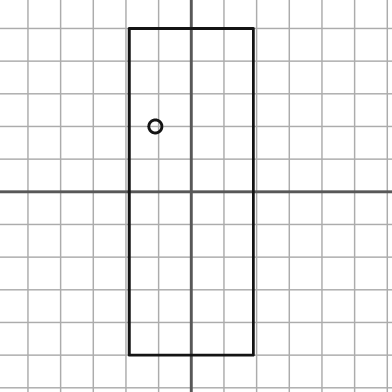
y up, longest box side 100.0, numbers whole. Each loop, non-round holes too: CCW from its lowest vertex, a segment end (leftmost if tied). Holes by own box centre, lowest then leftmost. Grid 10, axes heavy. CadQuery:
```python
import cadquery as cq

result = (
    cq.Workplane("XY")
    .moveTo(-19.0, -50.0)
    .lineTo(19.0, -50.0)
    .lineTo(19.0, 50.0)
    .lineTo(-19.0, 50.0)
    .close()
    .moveTo(-11.0, 20.0)
    .circle(2.0)
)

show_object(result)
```